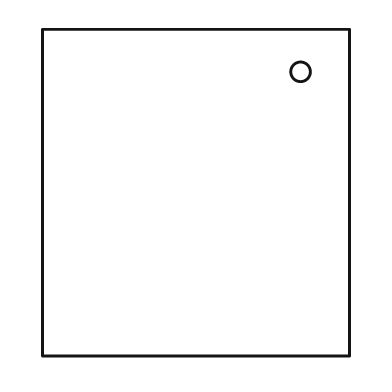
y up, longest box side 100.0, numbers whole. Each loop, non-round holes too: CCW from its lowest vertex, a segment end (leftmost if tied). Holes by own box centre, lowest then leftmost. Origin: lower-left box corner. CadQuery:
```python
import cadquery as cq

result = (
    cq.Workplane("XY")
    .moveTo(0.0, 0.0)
    .lineTo(94.0, 0.0)
    .lineTo(94.0, 100.0)
    .lineTo(0.0, 100.0)
    .close()
    .moveTo(79.0, 87.0)
    .circle(3.0)
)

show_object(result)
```